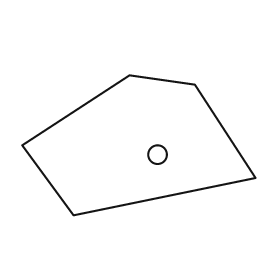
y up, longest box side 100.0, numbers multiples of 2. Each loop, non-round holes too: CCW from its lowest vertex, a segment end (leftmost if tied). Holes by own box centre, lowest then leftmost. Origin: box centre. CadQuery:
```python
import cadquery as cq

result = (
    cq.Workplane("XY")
    .moveTo(-28.0, -30.0)
    .lineTo(50.0, -14.0)
    .lineTo(24.0, 26.0)
    .lineTo(-4.0, 30.0)
    .lineTo(-50.0, 0.0)
    .close()
    .moveTo(8.0, -4.0)
    .circle(4.0)
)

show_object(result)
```